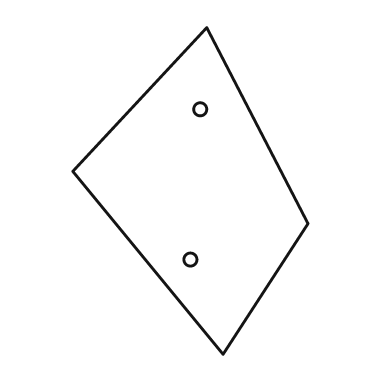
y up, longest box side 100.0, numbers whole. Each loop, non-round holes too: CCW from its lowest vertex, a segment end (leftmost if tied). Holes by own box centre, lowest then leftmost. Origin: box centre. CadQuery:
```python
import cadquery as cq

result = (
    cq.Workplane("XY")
    .moveTo(10.0, -50.0)
    .lineTo(36.0, -10.0)
    .lineTo(5.0, 50.0)
    .lineTo(-36.0, 6.0)
    .close()
    .moveTo(0.0, -21.0)
    .circle(2.0)
    .moveTo(3.0, 25.0)
    .circle(2.0)
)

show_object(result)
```